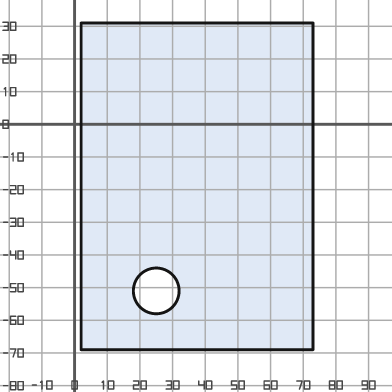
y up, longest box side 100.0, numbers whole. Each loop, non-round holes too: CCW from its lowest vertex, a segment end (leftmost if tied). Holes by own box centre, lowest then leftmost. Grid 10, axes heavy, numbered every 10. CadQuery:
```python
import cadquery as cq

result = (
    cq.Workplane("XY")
    .moveTo(2.0, -69.0)
    .lineTo(73.0, -69.0)
    .lineTo(73.0, 31.0)
    .lineTo(2.0, 31.0)
    .close()
    .moveTo(25.0, -51.0)
    .circle(7.0)
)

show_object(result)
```